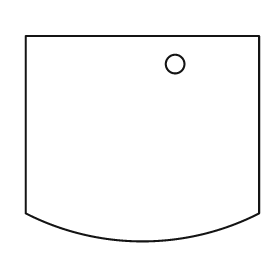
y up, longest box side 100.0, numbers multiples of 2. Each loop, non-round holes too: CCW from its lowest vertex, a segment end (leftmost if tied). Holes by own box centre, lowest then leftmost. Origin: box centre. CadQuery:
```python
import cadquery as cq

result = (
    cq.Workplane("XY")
    .moveTo(-50.0, -32.0)
    .threePointArc((0.0, -44.0), (50.0, -32.0))
    .lineTo(50.0, 44.0)
    .lineTo(-50.0, 44.0)
    .close()
    .moveTo(14.0, 32.0)
    .circle(4.0)
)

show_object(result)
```